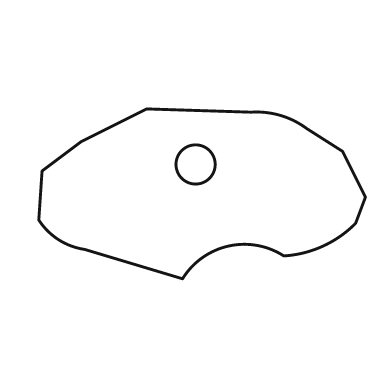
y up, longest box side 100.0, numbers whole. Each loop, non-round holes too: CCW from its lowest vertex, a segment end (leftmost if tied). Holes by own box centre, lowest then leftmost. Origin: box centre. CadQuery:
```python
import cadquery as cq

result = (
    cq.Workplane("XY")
    .moveTo(-6.0, -26.0)
    .threePointArc((8.0, -16.0), (25.0, -19.0))
    .threePointArc((37.0, -16.0), (47.0, -9.0))
    .lineTo(50.0, -1.0)
    .lineTo(43.0, 13.0)
    .lineTo(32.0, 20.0)
    .threePointArc((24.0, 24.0), (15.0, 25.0))
    .lineTo(-17.0, 26.0)
    .lineTo(-37.0, 16.0)
    .lineTo(-49.0, 7.0)
    .lineTo(-50.0, -8.0)
    .threePointArc((-44.0, -14.0), (-36.0, -17.0))
    .close()
    .moveTo(-2.0, 9.0)
    .circle(6.0)
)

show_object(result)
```